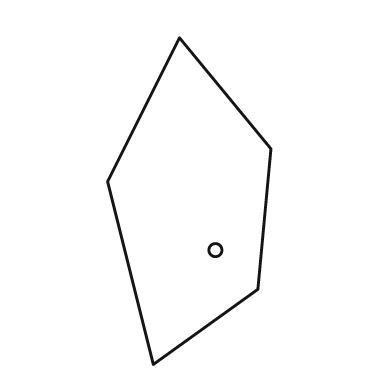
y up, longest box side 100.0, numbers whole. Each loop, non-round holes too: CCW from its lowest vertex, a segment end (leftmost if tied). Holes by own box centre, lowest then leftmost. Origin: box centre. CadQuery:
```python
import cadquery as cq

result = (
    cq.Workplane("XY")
    .moveTo(-11.0, -50.0)
    .lineTo(21.0, -27.0)
    .lineTo(25.0, 16.0)
    .lineTo(-3.0, 50.0)
    .lineTo(-25.0, 6.0)
    .close()
    .moveTo(8.0, -15.0)
    .circle(2.0)
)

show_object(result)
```